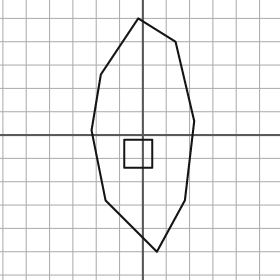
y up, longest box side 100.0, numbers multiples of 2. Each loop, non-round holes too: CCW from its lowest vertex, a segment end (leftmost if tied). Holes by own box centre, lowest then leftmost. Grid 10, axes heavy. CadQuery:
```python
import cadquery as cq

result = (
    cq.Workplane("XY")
    .moveTo(6.0, -50.0)
    .lineTo(18.0, -28.0)
    .lineTo(22.0, 6.0)
    .lineTo(14.0, 40.0)
    .lineTo(-2.0, 50.0)
    .lineTo(-18.0, 26.0)
    .lineTo(-22.0, 2.0)
    .lineTo(-16.0, -28.0)
    .close()
    .moveTo(-8.0, -14.0)
    .lineTo(4.0, -14.0)
    .lineTo(4.0, -2.0)
    .lineTo(-8.0, -2.0)
    .close()
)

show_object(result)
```